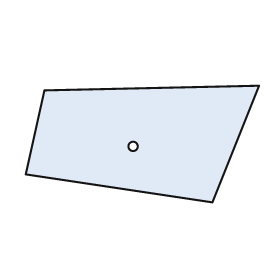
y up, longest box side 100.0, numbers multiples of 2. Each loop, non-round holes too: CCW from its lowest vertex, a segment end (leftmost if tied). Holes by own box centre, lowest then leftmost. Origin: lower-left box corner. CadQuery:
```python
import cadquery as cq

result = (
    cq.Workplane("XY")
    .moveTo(80.0, 0.0)
    .lineTo(100.0, 50.0)
    .lineTo(8.0, 48.0)
    .lineTo(0.0, 12.0)
    .close()
    .moveTo(46.0, 24.0)
    .circle(2.0)
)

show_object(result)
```